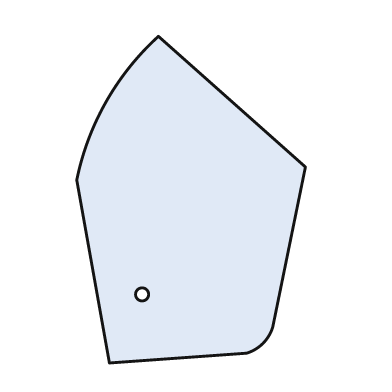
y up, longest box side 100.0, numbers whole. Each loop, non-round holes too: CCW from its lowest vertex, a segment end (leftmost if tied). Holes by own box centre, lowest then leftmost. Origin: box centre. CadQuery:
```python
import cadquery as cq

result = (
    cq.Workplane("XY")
    .moveTo(-25.0, -50.0)
    .lineTo(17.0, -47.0)
    .threePointArc((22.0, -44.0), (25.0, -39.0))
    .lineTo(35.0, 10.0)
    .lineTo(-10.0, 50.0)
    .threePointArc((-26.0, 30.0), (-35.0, 6.0))
    .close()
    .moveTo(-15.0, -29.0)
    .circle(2.0)
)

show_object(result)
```